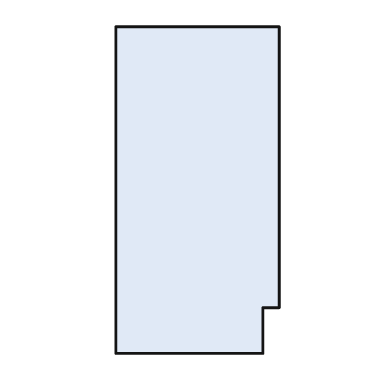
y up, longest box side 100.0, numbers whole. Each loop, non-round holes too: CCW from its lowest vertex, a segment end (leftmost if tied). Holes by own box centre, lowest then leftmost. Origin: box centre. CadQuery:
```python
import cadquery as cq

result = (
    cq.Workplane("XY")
    .moveTo(-25.0, -50.0)
    .lineTo(20.0, -50.0)
    .lineTo(20.0, -36.0)
    .lineTo(25.0, -36.0)
    .lineTo(25.0, 50.0)
    .lineTo(-25.0, 50.0)
    .close()
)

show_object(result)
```